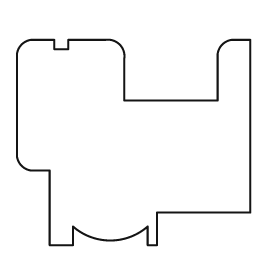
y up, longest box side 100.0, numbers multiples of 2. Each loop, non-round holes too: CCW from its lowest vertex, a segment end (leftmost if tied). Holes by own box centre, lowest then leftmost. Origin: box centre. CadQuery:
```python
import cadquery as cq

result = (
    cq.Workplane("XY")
    .moveTo(-36.0, -44.0)
    .lineTo(-26.0, -44.0)
    .lineTo(-26.0, -36.0)
    .threePointArc((-10.0, -42.0), (6.0, -36.0))
    .lineTo(6.0, -44.0)
    .lineTo(10.0, -44.0)
    .lineTo(10.0, -30.0)
    .lineTo(50.0, -30.0)
    .lineTo(50.0, 44.0)
    .lineTo(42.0, 44.0)
    .threePointArc((38.0, 42.0), (36.0, 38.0))
    .lineTo(36.0, 18.0)
    .lineTo(-4.0, 18.0)
    .lineTo(-4.0, 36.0)
    .threePointArc((-6.0, 42.0), (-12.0, 44.0))
    .lineTo(-28.0, 44.0)
    .lineTo(-28.0, 40.0)
    .lineTo(-34.0, 40.0)
    .lineTo(-34.0, 44.0)
    .lineTo(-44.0, 44.0)
    .threePointArc((-48.0, 42.0), (-50.0, 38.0))
    .lineTo(-50.0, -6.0)
    .threePointArc((-48.0, -10.0), (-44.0, -12.0))
    .lineTo(-36.0, -12.0)
    .close()
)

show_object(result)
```